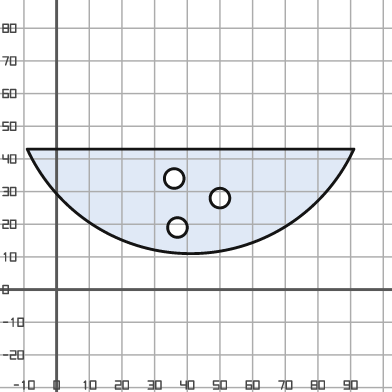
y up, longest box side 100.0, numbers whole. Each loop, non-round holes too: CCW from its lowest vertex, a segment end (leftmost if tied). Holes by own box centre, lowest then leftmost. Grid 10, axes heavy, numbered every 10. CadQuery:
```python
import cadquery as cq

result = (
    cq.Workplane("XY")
    .moveTo(-9.0, 43.0)
    .threePointArc((41.0, 11.0), (91.0, 43.0))
    .close()
    .moveTo(37.0, 19.0)
    .circle(3.0)
    .moveTo(50.0, 28.0)
    .circle(3.0)
    .moveTo(36.0, 34.0)
    .circle(3.0)
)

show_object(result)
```